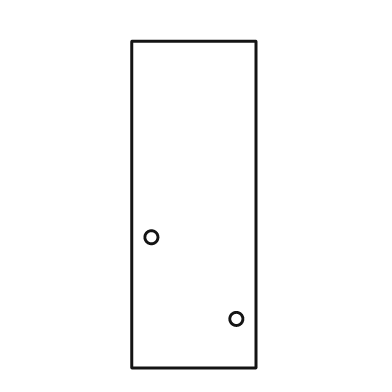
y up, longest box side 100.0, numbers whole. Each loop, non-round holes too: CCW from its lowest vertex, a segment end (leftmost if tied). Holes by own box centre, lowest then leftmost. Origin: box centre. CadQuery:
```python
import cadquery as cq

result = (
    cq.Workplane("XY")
    .moveTo(-19.0, -50.0)
    .lineTo(19.0, -50.0)
    .lineTo(19.0, 50.0)
    .lineTo(-19.0, 50.0)
    .close()
    .moveTo(13.0, -35.0)
    .circle(2.0)
    .moveTo(-13.0, -10.0)
    .circle(2.0)
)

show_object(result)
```